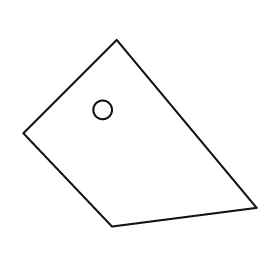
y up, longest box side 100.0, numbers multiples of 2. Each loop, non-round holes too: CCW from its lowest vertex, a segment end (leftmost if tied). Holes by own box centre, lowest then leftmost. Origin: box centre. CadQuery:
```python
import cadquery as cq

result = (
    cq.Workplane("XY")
    .moveTo(-12.0, -40.0)
    .lineTo(50.0, -32.0)
    .lineTo(-10.0, 40.0)
    .lineTo(-50.0, 0.0)
    .close()
    .moveTo(-16.0, 10.0)
    .circle(4.0)
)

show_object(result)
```